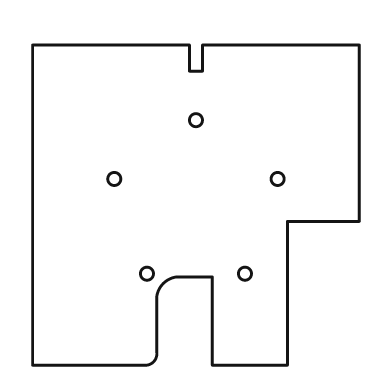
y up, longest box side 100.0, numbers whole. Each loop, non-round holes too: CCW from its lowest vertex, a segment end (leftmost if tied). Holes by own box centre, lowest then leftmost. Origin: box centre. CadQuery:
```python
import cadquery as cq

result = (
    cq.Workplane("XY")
    .moveTo(-50.0, -49.0)
    .lineTo(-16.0, -49.0)
    .threePointArc((-13.0, -48.0), (-12.0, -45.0))
    .lineTo(-12.0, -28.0)
    .threePointArc((-10.0, -24.0), (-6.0, -22.0))
    .lineTo(5.0, -22.0)
    .lineTo(5.0, -49.0)
    .lineTo(28.0, -49.0)
    .lineTo(28.0, -5.0)
    .lineTo(50.0, -5.0)
    .lineTo(50.0, 49.0)
    .lineTo(2.0, 49.0)
    .lineTo(2.0, 41.0)
    .lineTo(-2.0, 41.0)
    .lineTo(-2.0, 49.0)
    .lineTo(-50.0, 49.0)
    .close()
    .moveTo(-15.0, -21.0)
    .circle(2.0)
    .moveTo(15.0, -21.0)
    .circle(2.0)
    .moveTo(-25.0, 8.0)
    .circle(2.0)
    .moveTo(25.0, 8.0)
    .circle(2.0)
    .moveTo(0.0, 26.0)
    .circle(2.0)
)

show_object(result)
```